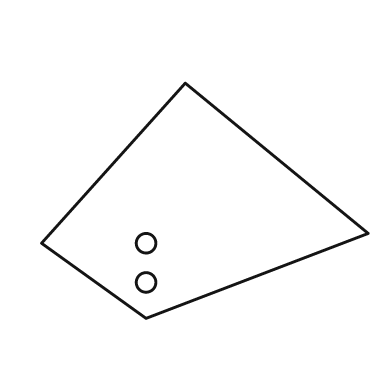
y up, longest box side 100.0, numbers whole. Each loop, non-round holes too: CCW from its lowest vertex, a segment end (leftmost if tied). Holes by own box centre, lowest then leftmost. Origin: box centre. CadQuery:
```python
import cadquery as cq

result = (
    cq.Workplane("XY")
    .moveTo(-18.0, -36.0)
    .lineTo(50.0, -10.0)
    .lineTo(-6.0, 36.0)
    .lineTo(-50.0, -13.0)
    .close()
    .moveTo(-18.0, -25.0)
    .circle(3.0)
    .moveTo(-18.0, -13.0)
    .circle(3.0)
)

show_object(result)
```